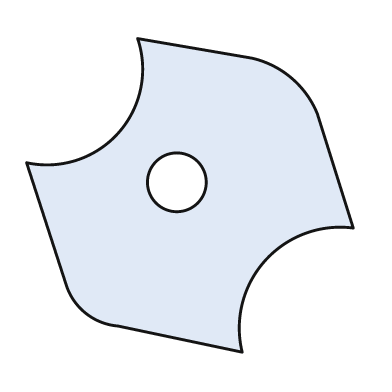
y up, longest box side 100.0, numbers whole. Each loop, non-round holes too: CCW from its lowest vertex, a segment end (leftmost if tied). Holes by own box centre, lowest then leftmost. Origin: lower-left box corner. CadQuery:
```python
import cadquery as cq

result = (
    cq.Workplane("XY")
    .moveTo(66.0, 0.0)
    .threePointArc((73.0, 28.0), (100.0, 38.0))
    .lineTo(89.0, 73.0)
    .threePointArc((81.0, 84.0), (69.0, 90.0))
    .lineTo(34.0, 96.0)
    .threePointArc((28.0, 67.0), (0.0, 58.0))
    .lineTo(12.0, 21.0)
    .threePointArc((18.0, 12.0), (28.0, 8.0))
    .close()
    .moveTo(46.0, 52.0)
    .circle(9.0)
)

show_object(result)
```